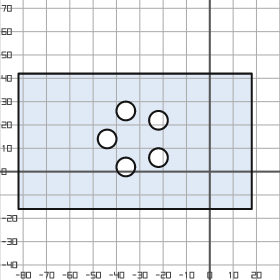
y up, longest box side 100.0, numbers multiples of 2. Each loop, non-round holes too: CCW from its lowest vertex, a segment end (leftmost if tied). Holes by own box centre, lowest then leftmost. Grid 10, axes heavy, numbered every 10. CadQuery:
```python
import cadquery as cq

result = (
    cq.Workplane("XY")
    .moveTo(-82.0, -16.0)
    .lineTo(18.0, -16.0)
    .lineTo(18.0, 42.0)
    .lineTo(-82.0, 42.0)
    .close()
    .moveTo(-36.0, 2.0)
    .circle(4.0)
    .moveTo(-22.0, 6.0)
    .circle(4.0)
    .moveTo(-44.0, 14.0)
    .circle(4.0)
    .moveTo(-22.0, 22.0)
    .circle(4.0)
    .moveTo(-36.0, 26.0)
    .circle(4.0)
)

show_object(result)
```